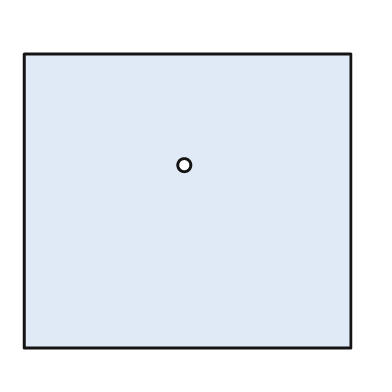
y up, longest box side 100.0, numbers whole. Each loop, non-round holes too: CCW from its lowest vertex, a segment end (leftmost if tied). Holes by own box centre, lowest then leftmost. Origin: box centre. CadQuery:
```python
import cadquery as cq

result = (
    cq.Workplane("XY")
    .moveTo(-50.0, -45.0)
    .lineTo(50.0, -45.0)
    .lineTo(50.0, 45.0)
    .lineTo(-50.0, 45.0)
    .close()
    .moveTo(-1.0, 11.0)
    .circle(2.0)
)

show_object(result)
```